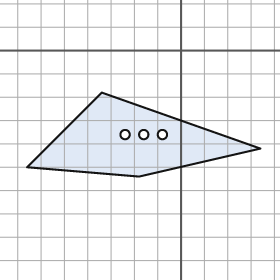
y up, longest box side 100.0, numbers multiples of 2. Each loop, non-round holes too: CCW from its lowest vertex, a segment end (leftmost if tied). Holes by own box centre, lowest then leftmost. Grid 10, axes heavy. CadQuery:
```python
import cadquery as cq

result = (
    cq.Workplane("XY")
    .moveTo(-18.0, -54.0)
    .lineTo(34.0, -42.0)
    .lineTo(-34.0, -18.0)
    .lineTo(-66.0, -50.0)
    .close()
    .moveTo(-24.0, -36.0)
    .circle(2.0)
    .moveTo(-16.0, -36.0)
    .circle(2.0)
    .moveTo(-8.0, -36.0)
    .circle(2.0)
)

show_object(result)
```